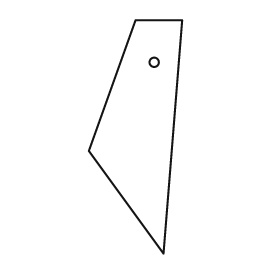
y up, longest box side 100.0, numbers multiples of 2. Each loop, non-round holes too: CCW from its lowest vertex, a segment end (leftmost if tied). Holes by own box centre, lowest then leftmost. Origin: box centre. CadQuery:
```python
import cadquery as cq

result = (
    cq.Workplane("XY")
    .moveTo(12.0, -50.0)
    .lineTo(20.0, 50.0)
    .lineTo(0.0, 50.0)
    .lineTo(-20.0, -6.0)
    .close()
    .moveTo(8.0, 32.0)
    .circle(2.0)
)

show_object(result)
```